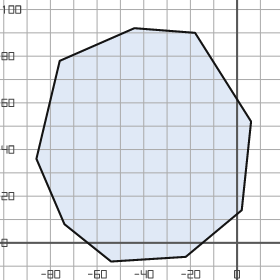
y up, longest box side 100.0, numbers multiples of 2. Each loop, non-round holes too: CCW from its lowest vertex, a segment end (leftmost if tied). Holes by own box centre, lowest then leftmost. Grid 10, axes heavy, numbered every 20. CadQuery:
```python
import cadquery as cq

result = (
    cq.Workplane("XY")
    .moveTo(-54.0, -8.0)
    .lineTo(-22.0, -6.0)
    .lineTo(2.0, 14.0)
    .lineTo(6.0, 52.0)
    .lineTo(-18.0, 90.0)
    .lineTo(-44.0, 92.0)
    .lineTo(-76.0, 78.0)
    .lineTo(-86.0, 36.0)
    .lineTo(-74.0, 8.0)
    .close()
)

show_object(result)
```